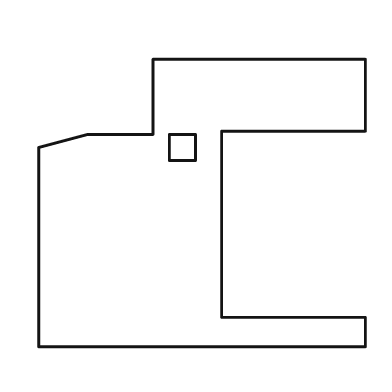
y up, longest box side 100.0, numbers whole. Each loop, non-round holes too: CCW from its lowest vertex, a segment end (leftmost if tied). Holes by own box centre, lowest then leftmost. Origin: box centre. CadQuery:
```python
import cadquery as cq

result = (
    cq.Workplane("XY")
    .moveTo(-50.0, -44.0)
    .lineTo(50.0, -44.0)
    .lineTo(50.0, -35.0)
    .lineTo(6.0, -35.0)
    .lineTo(6.0, 22.0)
    .lineTo(50.0, 22.0)
    .lineTo(50.0, 44.0)
    .lineTo(-15.0, 44.0)
    .lineTo(-15.0, 21.0)
    .lineTo(-35.0, 21.0)
    .lineTo(-50.0, 17.0)
    .close()
    .moveTo(-10.0, 13.0)
    .lineTo(-2.0, 13.0)
    .lineTo(-2.0, 21.0)
    .lineTo(-10.0, 21.0)
    .close()
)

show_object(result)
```